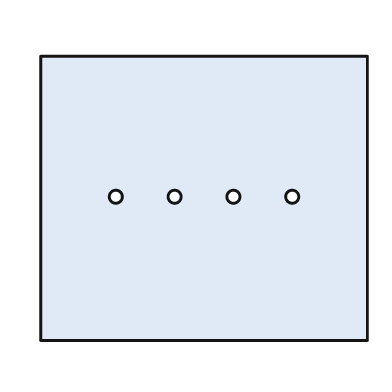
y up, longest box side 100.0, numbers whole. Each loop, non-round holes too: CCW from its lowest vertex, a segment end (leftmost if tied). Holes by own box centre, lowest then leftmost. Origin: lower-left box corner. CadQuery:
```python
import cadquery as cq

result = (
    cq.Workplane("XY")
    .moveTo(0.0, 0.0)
    .lineTo(100.0, 0.0)
    .lineTo(100.0, 87.0)
    .lineTo(0.0, 87.0)
    .close()
    .moveTo(23.0, 44.0)
    .circle(2.0)
    .moveTo(41.0, 44.0)
    .circle(2.0)
    .moveTo(59.0, 44.0)
    .circle(2.0)
    .moveTo(77.0, 44.0)
    .circle(2.0)
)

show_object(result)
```